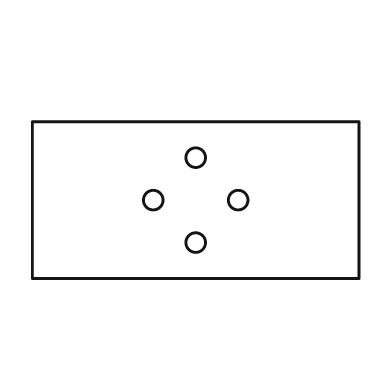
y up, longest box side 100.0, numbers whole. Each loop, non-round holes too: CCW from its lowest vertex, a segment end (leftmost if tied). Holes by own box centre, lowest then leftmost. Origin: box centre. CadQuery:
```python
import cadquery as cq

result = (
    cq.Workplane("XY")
    .moveTo(-50.0, -24.0)
    .lineTo(50.0, -24.0)
    .lineTo(50.0, 24.0)
    .lineTo(-50.0, 24.0)
    .close()
    .moveTo(0.0, -13.0)
    .circle(3.0)
    .moveTo(-13.0, 0.0)
    .circle(3.0)
    .moveTo(13.0, 0.0)
    .circle(3.0)
    .moveTo(0.0, 13.0)
    .circle(3.0)
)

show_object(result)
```